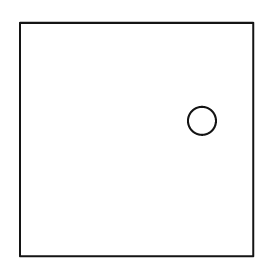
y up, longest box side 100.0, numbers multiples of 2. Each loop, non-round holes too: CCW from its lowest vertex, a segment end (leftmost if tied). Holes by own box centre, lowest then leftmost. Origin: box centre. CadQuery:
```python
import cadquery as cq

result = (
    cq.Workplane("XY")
    .moveTo(-50.0, -50.0)
    .lineTo(50.0, -50.0)
    .lineTo(50.0, 50.0)
    .lineTo(-50.0, 50.0)
    .close()
    .moveTo(28.0, 8.0)
    .circle(6.0)
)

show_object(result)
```